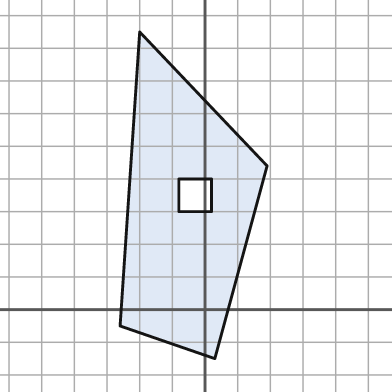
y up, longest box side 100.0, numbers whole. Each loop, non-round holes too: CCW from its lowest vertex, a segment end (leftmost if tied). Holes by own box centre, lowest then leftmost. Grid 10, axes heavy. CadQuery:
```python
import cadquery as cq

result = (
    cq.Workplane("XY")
    .moveTo(3.0, -15.0)
    .lineTo(19.0, 44.0)
    .lineTo(-20.0, 85.0)
    .lineTo(-26.0, -5.0)
    .close()
    .moveTo(-8.0, 30.0)
    .lineTo(2.0, 30.0)
    .lineTo(2.0, 40.0)
    .lineTo(-8.0, 40.0)
    .close()
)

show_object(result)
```